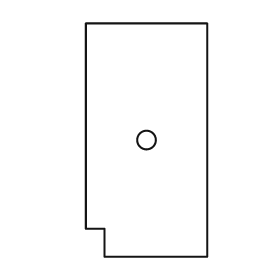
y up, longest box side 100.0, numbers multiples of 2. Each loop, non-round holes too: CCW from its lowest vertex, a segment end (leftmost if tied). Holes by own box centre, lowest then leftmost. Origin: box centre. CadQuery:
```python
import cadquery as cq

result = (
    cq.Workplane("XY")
    .moveTo(-18.0, -50.0)
    .lineTo(26.0, -50.0)
    .lineTo(26.0, 50.0)
    .lineTo(-26.0, 50.0)
    .lineTo(-26.0, -38.0)
    .lineTo(-18.0, -38.0)
    .close()
    .moveTo(0.0, 0.0)
    .circle(4.0)
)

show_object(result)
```